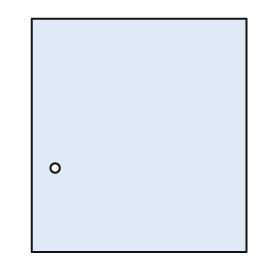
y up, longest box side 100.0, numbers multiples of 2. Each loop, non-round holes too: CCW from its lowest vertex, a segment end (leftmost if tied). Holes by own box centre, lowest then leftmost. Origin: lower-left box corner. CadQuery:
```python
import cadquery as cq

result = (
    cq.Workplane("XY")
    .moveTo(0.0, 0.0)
    .lineTo(92.0, 0.0)
    .lineTo(92.0, 100.0)
    .lineTo(0.0, 100.0)
    .close()
    .moveTo(10.0, 36.0)
    .circle(2.0)
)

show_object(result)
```